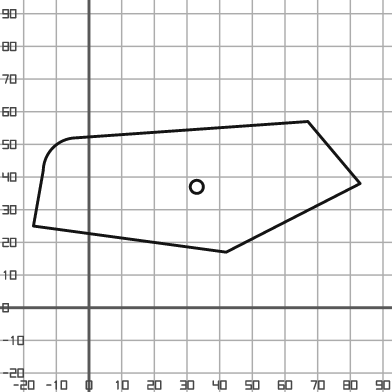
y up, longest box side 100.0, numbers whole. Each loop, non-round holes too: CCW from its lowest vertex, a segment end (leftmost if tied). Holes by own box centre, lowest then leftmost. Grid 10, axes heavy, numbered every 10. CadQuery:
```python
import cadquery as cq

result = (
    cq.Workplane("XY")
    .moveTo(42.0, 17.0)
    .lineTo(83.0, 38.0)
    .lineTo(67.0, 57.0)
    .lineTo(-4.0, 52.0)
    .threePointArc((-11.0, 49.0), (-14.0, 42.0))
    .lineTo(-17.0, 25.0)
    .close()
    .moveTo(33.0, 37.0)
    .circle(2.0)
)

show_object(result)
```